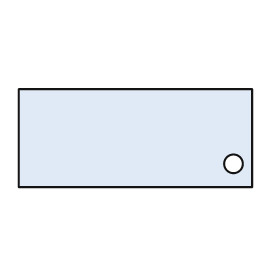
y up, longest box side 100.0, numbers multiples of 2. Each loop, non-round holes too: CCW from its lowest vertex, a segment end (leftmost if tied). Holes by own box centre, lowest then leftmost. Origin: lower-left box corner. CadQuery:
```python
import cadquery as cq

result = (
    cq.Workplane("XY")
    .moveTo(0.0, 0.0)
    .lineTo(100.0, 0.0)
    .lineTo(100.0, 42.0)
    .lineTo(0.0, 42.0)
    .close()
    .moveTo(92.0, 10.0)
    .circle(4.0)
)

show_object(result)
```